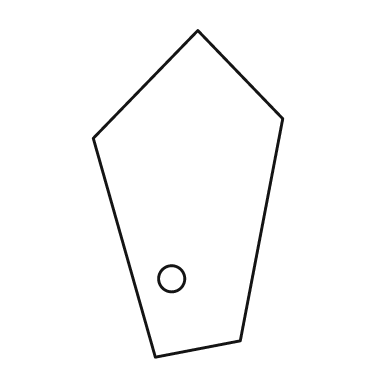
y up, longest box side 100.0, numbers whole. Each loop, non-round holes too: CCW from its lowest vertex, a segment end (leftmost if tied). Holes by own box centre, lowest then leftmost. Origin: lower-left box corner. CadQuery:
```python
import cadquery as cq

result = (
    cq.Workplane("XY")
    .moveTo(19.0, 0.0)
    .lineTo(45.0, 5.0)
    .lineTo(58.0, 73.0)
    .lineTo(32.0, 100.0)
    .lineTo(0.0, 67.0)
    .close()
    .moveTo(24.0, 24.0)
    .circle(4.0)
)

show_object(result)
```